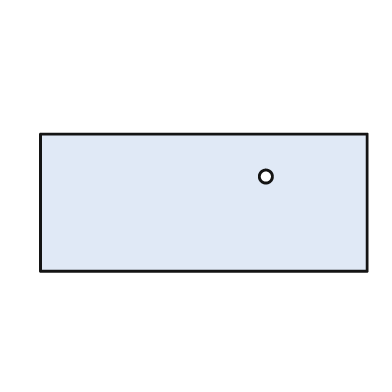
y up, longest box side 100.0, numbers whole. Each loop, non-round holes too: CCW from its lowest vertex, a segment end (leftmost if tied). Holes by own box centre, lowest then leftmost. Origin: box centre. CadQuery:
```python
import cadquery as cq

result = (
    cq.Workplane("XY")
    .moveTo(-50.0, -21.0)
    .lineTo(50.0, -21.0)
    .lineTo(50.0, 21.0)
    .lineTo(-50.0, 21.0)
    .close()
    .moveTo(19.0, 8.0)
    .circle(2.0)
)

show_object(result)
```